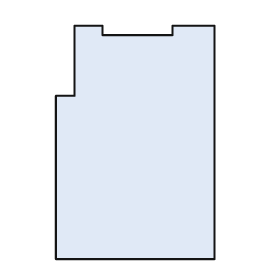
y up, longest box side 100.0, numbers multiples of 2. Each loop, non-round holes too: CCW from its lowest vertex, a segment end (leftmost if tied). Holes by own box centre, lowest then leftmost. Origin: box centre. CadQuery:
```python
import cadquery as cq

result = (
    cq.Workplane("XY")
    .moveTo(-34.0, -50.0)
    .lineTo(34.0, -50.0)
    .lineTo(34.0, 50.0)
    .lineTo(16.0, 50.0)
    .lineTo(16.0, 46.0)
    .lineTo(-14.0, 46.0)
    .lineTo(-14.0, 50.0)
    .lineTo(-26.0, 50.0)
    .lineTo(-26.0, 20.0)
    .lineTo(-34.0, 20.0)
    .close()
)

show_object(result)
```